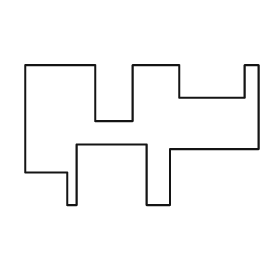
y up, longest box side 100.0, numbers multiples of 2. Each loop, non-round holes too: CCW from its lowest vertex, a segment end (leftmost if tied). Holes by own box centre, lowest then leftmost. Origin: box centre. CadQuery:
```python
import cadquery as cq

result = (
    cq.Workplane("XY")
    .moveTo(-32.0, -30.0)
    .lineTo(-28.0, -30.0)
    .lineTo(-28.0, -4.0)
    .lineTo(2.0, -4.0)
    .lineTo(2.0, -30.0)
    .lineTo(12.0, -30.0)
    .lineTo(12.0, -6.0)
    .lineTo(50.0, -6.0)
    .lineTo(50.0, 30.0)
    .lineTo(44.0, 30.0)
    .lineTo(44.0, 16.0)
    .lineTo(16.0, 16.0)
    .lineTo(16.0, 30.0)
    .lineTo(-4.0, 30.0)
    .lineTo(-4.0, 6.0)
    .lineTo(-20.0, 6.0)
    .lineTo(-20.0, 30.0)
    .lineTo(-50.0, 30.0)
    .lineTo(-50.0, -16.0)
    .lineTo(-32.0, -16.0)
    .close()
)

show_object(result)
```